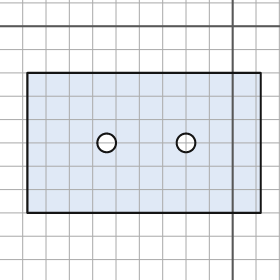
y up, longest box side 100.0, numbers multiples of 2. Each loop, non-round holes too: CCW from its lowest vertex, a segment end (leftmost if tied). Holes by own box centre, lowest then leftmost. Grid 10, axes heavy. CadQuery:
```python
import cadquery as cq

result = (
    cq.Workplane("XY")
    .moveTo(-88.0, -80.0)
    .lineTo(12.0, -80.0)
    .lineTo(12.0, -20.0)
    .lineTo(-88.0, -20.0)
    .close()
    .moveTo(-54.0, -50.0)
    .circle(4.0)
    .moveTo(-20.0, -50.0)
    .circle(4.0)
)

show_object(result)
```